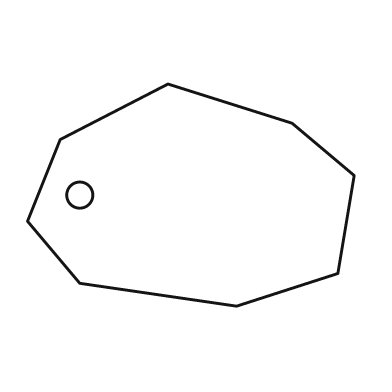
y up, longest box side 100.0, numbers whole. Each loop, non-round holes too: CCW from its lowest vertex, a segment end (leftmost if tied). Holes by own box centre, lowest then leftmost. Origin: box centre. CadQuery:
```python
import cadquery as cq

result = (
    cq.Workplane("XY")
    .moveTo(14.0, -34.0)
    .lineTo(45.0, -24.0)
    .lineTo(50.0, 6.0)
    .lineTo(31.0, 22.0)
    .lineTo(-7.0, 34.0)
    .lineTo(-40.0, 17.0)
    .lineTo(-50.0, -8.0)
    .lineTo(-34.0, -27.0)
    .close()
    .moveTo(-34.0, 0.0)
    .circle(4.0)
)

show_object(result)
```